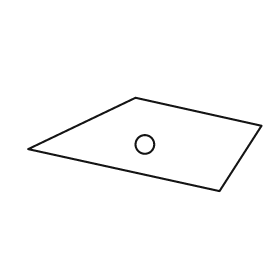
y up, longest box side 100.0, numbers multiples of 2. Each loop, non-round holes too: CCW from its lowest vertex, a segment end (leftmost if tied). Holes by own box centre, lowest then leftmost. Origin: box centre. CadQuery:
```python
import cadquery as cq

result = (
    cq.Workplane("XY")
    .moveTo(32.0, -20.0)
    .lineTo(50.0, 8.0)
    .lineTo(-4.0, 20.0)
    .lineTo(-50.0, -2.0)
    .close()
    .moveTo(0.0, 0.0)
    .circle(4.0)
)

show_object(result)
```